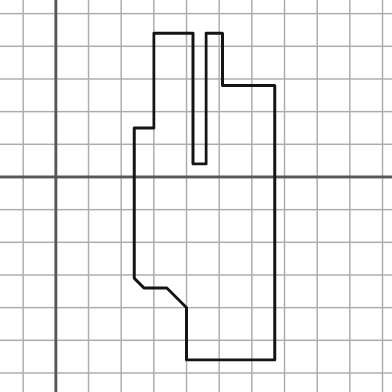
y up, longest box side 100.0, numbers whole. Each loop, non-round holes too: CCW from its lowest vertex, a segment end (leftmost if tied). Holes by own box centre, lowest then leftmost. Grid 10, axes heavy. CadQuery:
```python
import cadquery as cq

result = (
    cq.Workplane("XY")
    .moveTo(40.0, -56.0)
    .lineTo(67.0, -56.0)
    .lineTo(67.0, 28.0)
    .lineTo(51.0, 28.0)
    .lineTo(51.0, 44.0)
    .lineTo(46.0, 44.0)
    .lineTo(46.0, 4.0)
    .lineTo(42.0, 4.0)
    .lineTo(42.0, 44.0)
    .lineTo(30.0, 44.0)
    .lineTo(30.0, 15.0)
    .lineTo(24.0, 15.0)
    .lineTo(24.0, -31.0)
    .lineTo(27.0, -34.0)
    .lineTo(34.0, -34.0)
    .lineTo(40.0, -40.0)
    .close()
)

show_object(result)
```